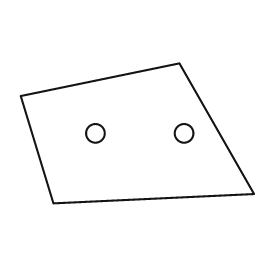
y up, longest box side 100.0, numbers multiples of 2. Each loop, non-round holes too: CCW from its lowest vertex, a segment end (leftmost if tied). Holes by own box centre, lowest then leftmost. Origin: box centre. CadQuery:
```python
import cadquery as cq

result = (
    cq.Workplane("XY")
    .moveTo(-36.0, -30.0)
    .lineTo(50.0, -26.0)
    .lineTo(18.0, 30.0)
    .lineTo(-50.0, 16.0)
    .close()
    .moveTo(-18.0, 0.0)
    .circle(4.0)
    .moveTo(20.0, 0.0)
    .circle(4.0)
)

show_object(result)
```